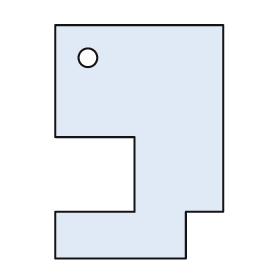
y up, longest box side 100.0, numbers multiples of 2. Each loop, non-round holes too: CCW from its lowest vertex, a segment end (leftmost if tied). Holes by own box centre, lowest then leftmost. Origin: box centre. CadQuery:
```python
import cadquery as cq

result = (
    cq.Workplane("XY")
    .moveTo(-36.0, -50.0)
    .lineTo(20.0, -50.0)
    .lineTo(20.0, -30.0)
    .lineTo(36.0, -30.0)
    .lineTo(36.0, 50.0)
    .lineTo(-36.0, 50.0)
    .lineTo(-36.0, 2.0)
    .lineTo(-2.0, 2.0)
    .lineTo(-2.0, -30.0)
    .lineTo(-36.0, -30.0)
    .close()
    .moveTo(-22.0, 36.0)
    .circle(4.0)
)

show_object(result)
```